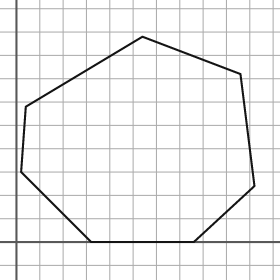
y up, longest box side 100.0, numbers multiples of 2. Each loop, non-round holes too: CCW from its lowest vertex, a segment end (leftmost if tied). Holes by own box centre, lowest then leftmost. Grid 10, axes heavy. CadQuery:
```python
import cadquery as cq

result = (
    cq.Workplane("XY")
    .moveTo(32.0, 0.0)
    .lineTo(76.0, 0.0)
    .lineTo(102.0, 24.0)
    .lineTo(96.0, 72.0)
    .lineTo(54.0, 88.0)
    .lineTo(4.0, 58.0)
    .lineTo(2.0, 30.0)
    .close()
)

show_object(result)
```